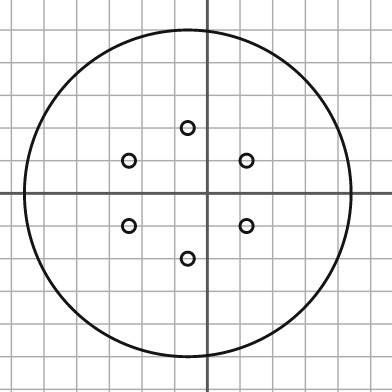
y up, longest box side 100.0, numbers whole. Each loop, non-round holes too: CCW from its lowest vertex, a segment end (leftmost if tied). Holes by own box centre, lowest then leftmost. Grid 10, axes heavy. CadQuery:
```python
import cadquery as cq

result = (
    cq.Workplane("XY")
    .moveTo(-6.0, 0.0)
    .circle(50.0)
    .moveTo(-6.0, -20.0)
    .circle(2.0)
    .moveTo(-24.0, -10.0)
    .circle(2.0)
    .moveTo(12.0, -10.0)
    .circle(2.0)
    .moveTo(-24.0, 10.0)
    .circle(2.0)
    .moveTo(12.0, 10.0)
    .circle(2.0)
    .moveTo(-6.0, 20.0)
    .circle(2.0)
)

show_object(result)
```